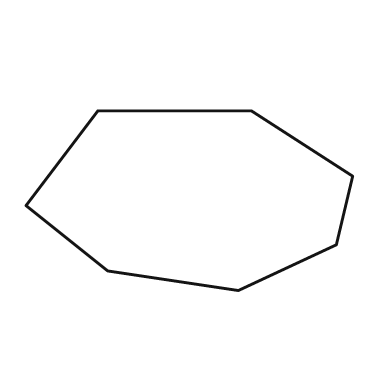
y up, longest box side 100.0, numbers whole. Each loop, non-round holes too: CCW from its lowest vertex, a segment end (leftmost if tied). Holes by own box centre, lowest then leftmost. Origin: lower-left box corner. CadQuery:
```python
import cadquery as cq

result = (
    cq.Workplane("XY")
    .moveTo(65.0, 0.0)
    .lineTo(95.0, 14.0)
    .lineTo(100.0, 35.0)
    .lineTo(69.0, 55.0)
    .lineTo(22.0, 55.0)
    .lineTo(0.0, 26.0)
    .lineTo(25.0, 6.0)
    .close()
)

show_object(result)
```